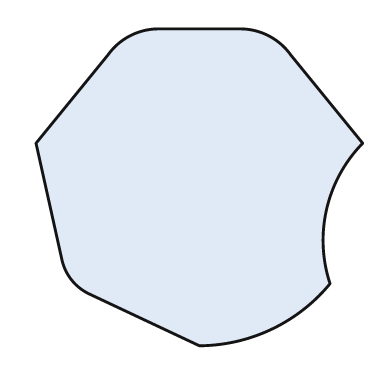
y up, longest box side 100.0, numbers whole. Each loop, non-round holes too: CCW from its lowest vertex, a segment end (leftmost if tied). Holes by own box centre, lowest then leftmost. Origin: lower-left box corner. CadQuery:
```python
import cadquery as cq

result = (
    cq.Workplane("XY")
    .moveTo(50.0, 0.0)
    .threePointArc((72.0, 5.0), (90.0, 19.0))
    .threePointArc((89.0, 42.0), (100.0, 62.0))
    .lineTo(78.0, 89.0)
    .threePointArc((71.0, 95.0), (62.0, 97.0))
    .lineTo(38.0, 97.0)
    .threePointArc((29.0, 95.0), (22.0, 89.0))
    .lineTo(0.0, 62.0)
    .lineTo(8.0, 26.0)
    .threePointArc((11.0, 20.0), (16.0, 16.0))
    .close()
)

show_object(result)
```